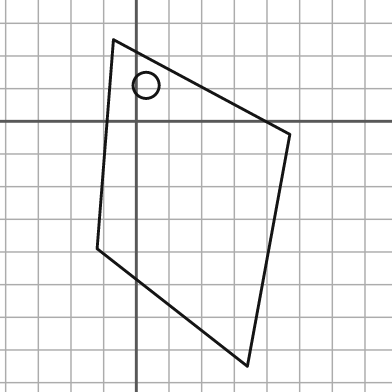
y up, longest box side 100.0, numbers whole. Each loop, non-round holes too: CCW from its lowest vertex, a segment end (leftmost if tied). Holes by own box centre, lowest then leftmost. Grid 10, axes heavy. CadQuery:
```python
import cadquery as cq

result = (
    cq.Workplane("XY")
    .moveTo(34.0, -75.0)
    .lineTo(47.0, -4.0)
    .lineTo(-7.0, 25.0)
    .lineTo(-12.0, -39.0)
    .close()
    .moveTo(3.0, 11.0)
    .circle(4.0)
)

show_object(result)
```